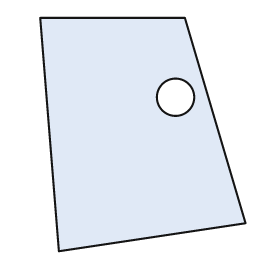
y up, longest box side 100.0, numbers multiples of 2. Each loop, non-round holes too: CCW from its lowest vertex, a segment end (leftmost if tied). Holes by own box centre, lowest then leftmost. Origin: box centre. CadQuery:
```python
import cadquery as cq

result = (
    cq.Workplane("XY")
    .moveTo(-36.0, -50.0)
    .lineTo(44.0, -38.0)
    .lineTo(18.0, 50.0)
    .lineTo(-44.0, 50.0)
    .close()
    .moveTo(14.0, 16.0)
    .circle(8.0)
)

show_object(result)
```